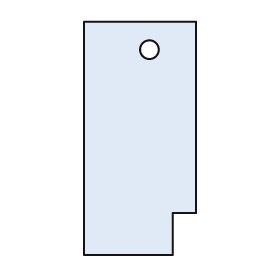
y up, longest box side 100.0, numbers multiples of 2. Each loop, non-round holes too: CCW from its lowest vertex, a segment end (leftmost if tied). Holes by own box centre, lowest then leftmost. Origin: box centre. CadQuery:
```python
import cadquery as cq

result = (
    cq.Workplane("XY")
    .moveTo(-24.0, -50.0)
    .lineTo(14.0, -50.0)
    .lineTo(14.0, -32.0)
    .lineTo(24.0, -32.0)
    .lineTo(24.0, 50.0)
    .lineTo(-24.0, 50.0)
    .close()
    .moveTo(4.0, 38.0)
    .circle(4.0)
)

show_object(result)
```